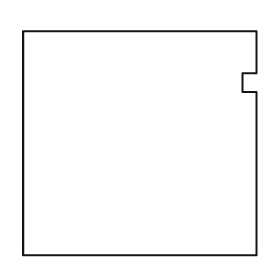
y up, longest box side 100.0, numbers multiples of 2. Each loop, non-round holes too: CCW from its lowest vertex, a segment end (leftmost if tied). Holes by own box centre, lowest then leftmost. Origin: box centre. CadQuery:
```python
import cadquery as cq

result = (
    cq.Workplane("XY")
    .moveTo(-50.0, -48.0)
    .lineTo(50.0, -48.0)
    .lineTo(50.0, 22.0)
    .lineTo(44.0, 22.0)
    .lineTo(44.0, 30.0)
    .lineTo(50.0, 30.0)
    .lineTo(50.0, 48.0)
    .lineTo(-50.0, 48.0)
    .close()
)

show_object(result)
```